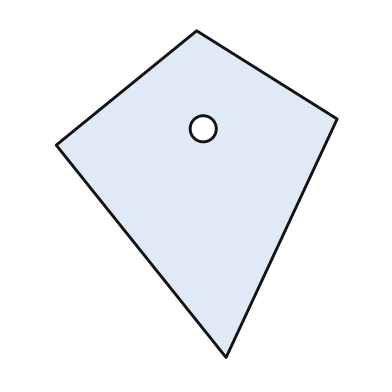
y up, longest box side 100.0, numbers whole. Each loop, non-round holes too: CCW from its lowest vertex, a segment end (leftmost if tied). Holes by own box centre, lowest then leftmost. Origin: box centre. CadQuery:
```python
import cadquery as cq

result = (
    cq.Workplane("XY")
    .moveTo(9.0, -50.0)
    .lineTo(43.0, 23.0)
    .lineTo(0.0, 50.0)
    .lineTo(-43.0, 15.0)
    .close()
    .moveTo(2.0, 20.0)
    .circle(4.0)
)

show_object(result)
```